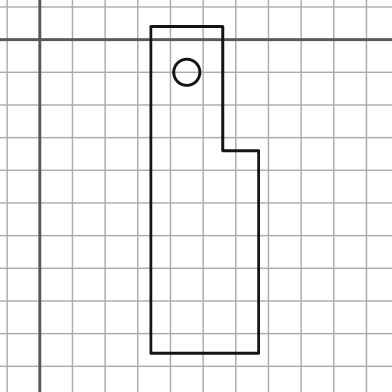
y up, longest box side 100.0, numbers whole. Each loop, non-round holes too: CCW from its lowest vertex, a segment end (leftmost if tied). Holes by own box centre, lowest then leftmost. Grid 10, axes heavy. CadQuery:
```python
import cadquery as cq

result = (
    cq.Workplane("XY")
    .moveTo(34.0, -96.0)
    .lineTo(67.0, -96.0)
    .lineTo(67.0, -34.0)
    .lineTo(56.0, -34.0)
    .lineTo(56.0, 4.0)
    .lineTo(34.0, 4.0)
    .close()
    .moveTo(45.0, -10.0)
    .circle(4.0)
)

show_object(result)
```